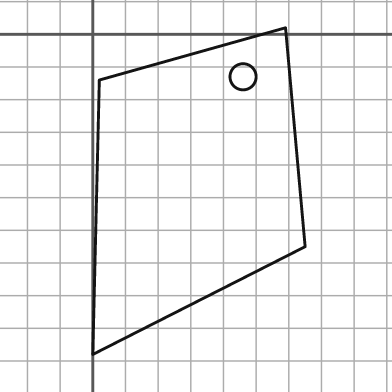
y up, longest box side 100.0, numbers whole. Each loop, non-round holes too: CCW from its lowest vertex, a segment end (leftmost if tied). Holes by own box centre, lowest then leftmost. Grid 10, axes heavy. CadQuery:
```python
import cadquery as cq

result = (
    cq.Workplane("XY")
    .moveTo(0.0, -98.0)
    .lineTo(65.0, -65.0)
    .lineTo(59.0, 2.0)
    .lineTo(2.0, -14.0)
    .close()
    .moveTo(46.0, -13.0)
    .circle(4.0)
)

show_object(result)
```